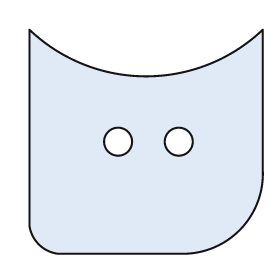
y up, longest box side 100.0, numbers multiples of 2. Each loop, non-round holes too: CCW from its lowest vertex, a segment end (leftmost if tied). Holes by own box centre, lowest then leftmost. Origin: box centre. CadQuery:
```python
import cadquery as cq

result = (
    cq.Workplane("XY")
    .moveTo(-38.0, -48.0)
    .lineTo(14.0, -48.0)
    .threePointArc((40.0, -38.0), (50.0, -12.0))
    .lineTo(50.0, 48.0)
    .threePointArc((0.0, 28.0), (-50.0, 48.0))
    .lineTo(-50.0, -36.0)
    .threePointArc((-46.0, -44.0), (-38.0, -48.0))
    .close()
    .moveTo(-12.0, 0.0)
    .circle(6.0)
    .moveTo(14.0, 0.0)
    .circle(6.0)
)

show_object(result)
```